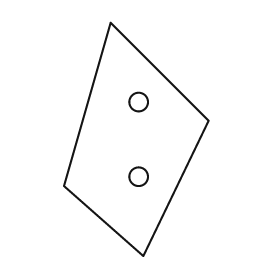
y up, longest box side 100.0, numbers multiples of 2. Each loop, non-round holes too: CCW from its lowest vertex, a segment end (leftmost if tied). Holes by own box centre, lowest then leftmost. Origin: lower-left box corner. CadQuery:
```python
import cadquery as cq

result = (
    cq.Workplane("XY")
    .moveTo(34.0, 0.0)
    .lineTo(62.0, 58.0)
    .lineTo(20.0, 100.0)
    .lineTo(0.0, 30.0)
    .close()
    .moveTo(32.0, 34.0)
    .circle(4.0)
    .moveTo(32.0, 66.0)
    .circle(4.0)
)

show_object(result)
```